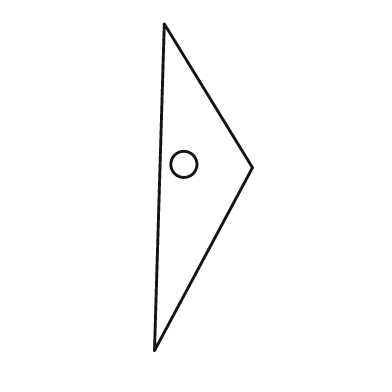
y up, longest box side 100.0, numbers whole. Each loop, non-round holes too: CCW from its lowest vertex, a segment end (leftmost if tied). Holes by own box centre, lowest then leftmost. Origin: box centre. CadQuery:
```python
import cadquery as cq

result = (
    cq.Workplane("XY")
    .moveTo(-15.0, -50.0)
    .lineTo(15.0, 6.0)
    .lineTo(-12.0, 50.0)
    .close()
    .moveTo(-6.0, 7.0)
    .circle(4.0)
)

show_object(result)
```